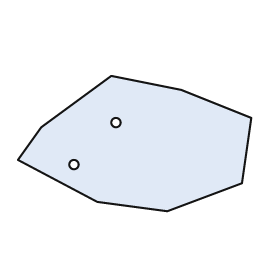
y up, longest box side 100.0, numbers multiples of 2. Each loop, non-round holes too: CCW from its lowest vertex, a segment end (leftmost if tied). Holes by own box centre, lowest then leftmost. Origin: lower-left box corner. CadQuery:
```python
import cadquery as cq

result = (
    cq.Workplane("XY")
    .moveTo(64.0, 0.0)
    .lineTo(96.0, 12.0)
    .lineTo(100.0, 40.0)
    .lineTo(70.0, 52.0)
    .lineTo(40.0, 58.0)
    .lineTo(10.0, 36.0)
    .lineTo(0.0, 22.0)
    .lineTo(34.0, 4.0)
    .close()
    .moveTo(24.0, 20.0)
    .circle(2.0)
    .moveTo(42.0, 38.0)
    .circle(2.0)
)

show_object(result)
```